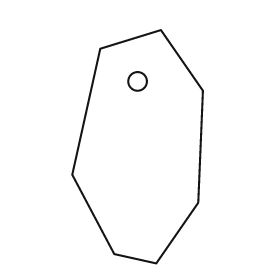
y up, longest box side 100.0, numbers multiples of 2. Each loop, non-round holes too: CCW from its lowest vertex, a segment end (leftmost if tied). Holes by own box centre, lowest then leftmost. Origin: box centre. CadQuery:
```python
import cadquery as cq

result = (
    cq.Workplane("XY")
    .moveTo(8.0, -50.0)
    .lineTo(26.0, -24.0)
    .lineTo(28.0, 24.0)
    .lineTo(10.0, 50.0)
    .lineTo(-16.0, 42.0)
    .lineTo(-28.0, -12.0)
    .lineTo(-10.0, -46.0)
    .close()
    .moveTo(0.0, 28.0)
    .circle(4.0)
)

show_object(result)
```